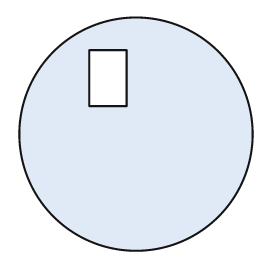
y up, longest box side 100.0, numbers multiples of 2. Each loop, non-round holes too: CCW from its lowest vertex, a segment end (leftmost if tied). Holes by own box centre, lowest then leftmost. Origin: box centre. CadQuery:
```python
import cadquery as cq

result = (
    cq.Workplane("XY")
    .moveTo(0.0, 0.0)
    .circle(50.0)
    .moveTo(-20.0, 12.0)
    .lineTo(-4.0, 12.0)
    .lineTo(-4.0, 36.0)
    .lineTo(-20.0, 36.0)
    .close()
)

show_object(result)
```